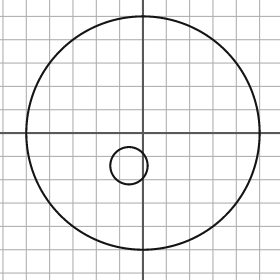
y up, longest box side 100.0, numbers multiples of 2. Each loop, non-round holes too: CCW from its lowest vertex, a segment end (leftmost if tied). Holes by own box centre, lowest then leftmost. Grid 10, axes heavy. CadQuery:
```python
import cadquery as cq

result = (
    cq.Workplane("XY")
    .moveTo(0.0, 0.0)
    .circle(50.0)
    .moveTo(-6.0, -14.0)
    .circle(8.0)
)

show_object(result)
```